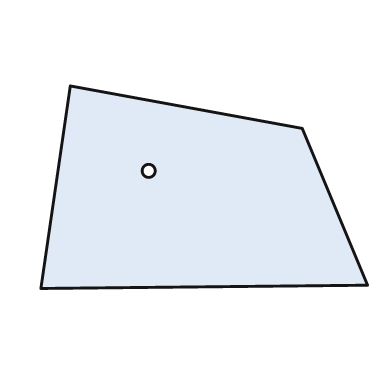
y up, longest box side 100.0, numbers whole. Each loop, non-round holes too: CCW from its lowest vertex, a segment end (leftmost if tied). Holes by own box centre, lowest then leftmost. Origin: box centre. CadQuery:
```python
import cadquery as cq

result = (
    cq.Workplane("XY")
    .moveTo(-50.0, -31.0)
    .lineTo(50.0, -30.0)
    .lineTo(30.0, 18.0)
    .lineTo(-41.0, 31.0)
    .close()
    .moveTo(-17.0, 5.0)
    .circle(2.0)
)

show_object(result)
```